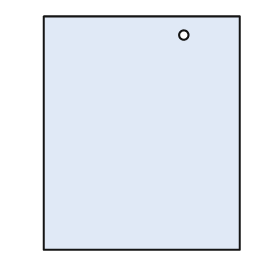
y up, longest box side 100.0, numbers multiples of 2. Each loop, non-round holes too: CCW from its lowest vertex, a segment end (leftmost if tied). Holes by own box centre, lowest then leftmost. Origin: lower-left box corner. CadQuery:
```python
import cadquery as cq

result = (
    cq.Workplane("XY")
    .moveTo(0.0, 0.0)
    .lineTo(84.0, 0.0)
    .lineTo(84.0, 100.0)
    .lineTo(0.0, 100.0)
    .close()
    .moveTo(60.0, 92.0)
    .circle(2.0)
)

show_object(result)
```